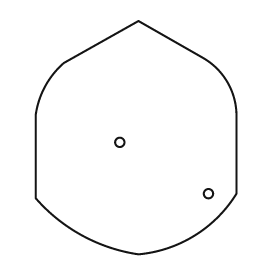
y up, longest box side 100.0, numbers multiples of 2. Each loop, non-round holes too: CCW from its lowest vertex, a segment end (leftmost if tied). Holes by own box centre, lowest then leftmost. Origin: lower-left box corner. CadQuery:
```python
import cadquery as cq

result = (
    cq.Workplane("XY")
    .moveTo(44.0, 0.0)
    .threePointArc((68.0, 8.0), (86.0, 26.0))
    .lineTo(86.0, 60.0)
    .threePointArc((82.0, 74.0), (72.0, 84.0))
    .lineTo(44.0, 100.0)
    .lineTo(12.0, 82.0)
    .threePointArc((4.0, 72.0), (0.0, 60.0))
    .lineTo(0.0, 24.0)
    .threePointArc((20.0, 8.0), (44.0, 0.0))
    .close()
    .moveTo(74.0, 26.0)
    .circle(2.0)
    .moveTo(36.0, 48.0)
    .circle(2.0)
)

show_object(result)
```